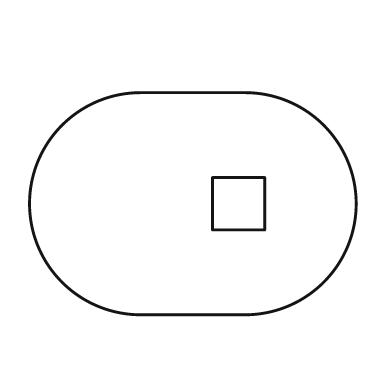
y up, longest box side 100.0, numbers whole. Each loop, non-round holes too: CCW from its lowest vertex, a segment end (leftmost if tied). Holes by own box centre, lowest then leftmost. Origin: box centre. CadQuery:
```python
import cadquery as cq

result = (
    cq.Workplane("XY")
    .moveTo(-16.0, -34.0)
    .lineTo(16.0, -34.0)
    .threePointArc((50.0, 0.0), (16.0, 34.0))
    .lineTo(-16.0, 34.0)
    .threePointArc((-50.0, 0.0), (-16.0, -34.0))
    .close()
    .moveTo(6.0, -8.0)
    .lineTo(22.0, -8.0)
    .lineTo(22.0, 8.0)
    .lineTo(6.0, 8.0)
    .close()
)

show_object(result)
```